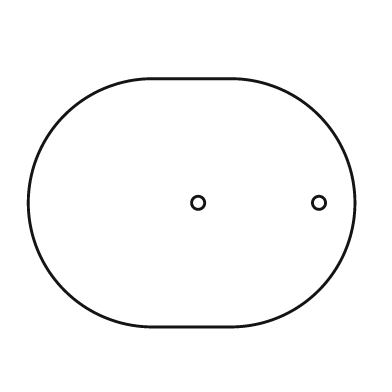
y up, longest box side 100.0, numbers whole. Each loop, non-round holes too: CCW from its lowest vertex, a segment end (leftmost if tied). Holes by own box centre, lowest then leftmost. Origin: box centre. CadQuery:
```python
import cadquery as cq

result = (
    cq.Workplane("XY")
    .moveTo(-12.0, -38.0)
    .lineTo(12.0, -38.0)
    .threePointArc((50.0, 0.0), (12.0, 38.0))
    .lineTo(-12.0, 38.0)
    .threePointArc((-50.0, 0.0), (-12.0, -38.0))
    .close()
    .moveTo(2.0, 0.0)
    .circle(2.0)
    .moveTo(39.0, 0.0)
    .circle(2.0)
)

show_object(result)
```